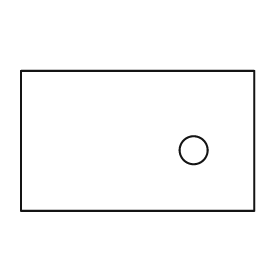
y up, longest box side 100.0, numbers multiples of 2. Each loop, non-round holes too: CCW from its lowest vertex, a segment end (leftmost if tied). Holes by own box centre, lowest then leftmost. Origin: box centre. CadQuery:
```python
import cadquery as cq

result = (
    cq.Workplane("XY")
    .moveTo(-50.0, -30.0)
    .lineTo(50.0, -30.0)
    .lineTo(50.0, 30.0)
    .lineTo(-50.0, 30.0)
    .close()
    .moveTo(24.0, -4.0)
    .circle(6.0)
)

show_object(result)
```